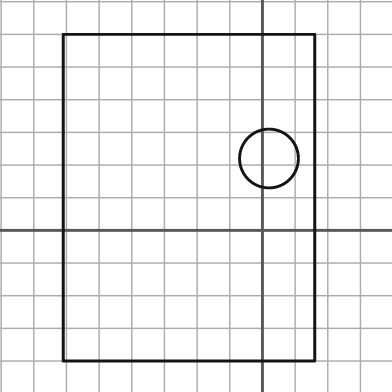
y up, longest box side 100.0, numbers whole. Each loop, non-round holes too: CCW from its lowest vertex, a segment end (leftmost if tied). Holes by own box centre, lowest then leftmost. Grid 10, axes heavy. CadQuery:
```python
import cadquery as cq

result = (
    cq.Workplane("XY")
    .moveTo(-61.0, -40.0)
    .lineTo(16.0, -40.0)
    .lineTo(16.0, 60.0)
    .lineTo(-61.0, 60.0)
    .close()
    .moveTo(2.0, 22.0)
    .circle(9.0)
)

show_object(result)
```